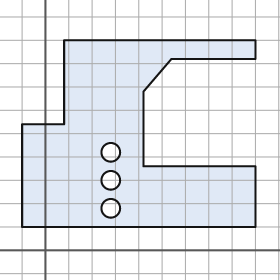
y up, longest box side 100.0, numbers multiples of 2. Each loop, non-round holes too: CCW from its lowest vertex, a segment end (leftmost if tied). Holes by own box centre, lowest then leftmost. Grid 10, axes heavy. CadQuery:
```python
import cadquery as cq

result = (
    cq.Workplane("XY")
    .moveTo(-10.0, 10.0)
    .lineTo(90.0, 10.0)
    .lineTo(90.0, 36.0)
    .lineTo(42.0, 36.0)
    .lineTo(42.0, 68.0)
    .lineTo(54.0, 82.0)
    .lineTo(90.0, 82.0)
    .lineTo(90.0, 90.0)
    .lineTo(8.0, 90.0)
    .lineTo(8.0, 54.0)
    .lineTo(-10.0, 54.0)
    .close()
    .moveTo(28.0, 18.0)
    .circle(4.0)
    .moveTo(28.0, 30.0)
    .circle(4.0)
    .moveTo(28.0, 42.0)
    .circle(4.0)
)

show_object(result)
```